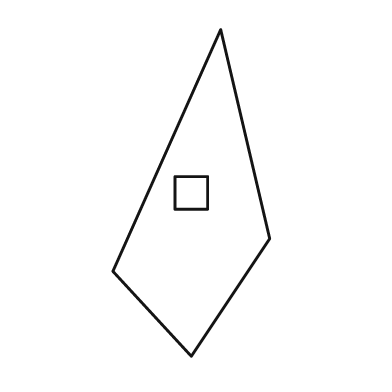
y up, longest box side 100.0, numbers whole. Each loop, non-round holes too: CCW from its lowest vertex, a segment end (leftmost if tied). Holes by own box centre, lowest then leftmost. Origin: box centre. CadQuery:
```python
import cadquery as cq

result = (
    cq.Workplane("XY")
    .moveTo(0.0, -50.0)
    .lineTo(24.0, -14.0)
    .lineTo(9.0, 50.0)
    .lineTo(-24.0, -24.0)
    .close()
    .moveTo(-5.0, -5.0)
    .lineTo(5.0, -5.0)
    .lineTo(5.0, 5.0)
    .lineTo(-5.0, 5.0)
    .close()
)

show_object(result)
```